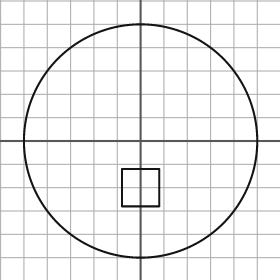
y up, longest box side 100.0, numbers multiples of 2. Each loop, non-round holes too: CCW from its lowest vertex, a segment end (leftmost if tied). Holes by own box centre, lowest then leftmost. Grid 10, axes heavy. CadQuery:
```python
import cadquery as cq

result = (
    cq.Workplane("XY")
    .moveTo(0.0, 0.0)
    .circle(50.0)
    .moveTo(-8.0, -28.0)
    .lineTo(8.0, -28.0)
    .lineTo(8.0, -12.0)
    .lineTo(-8.0, -12.0)
    .close()
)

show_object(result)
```